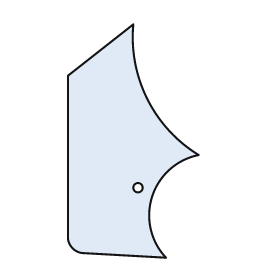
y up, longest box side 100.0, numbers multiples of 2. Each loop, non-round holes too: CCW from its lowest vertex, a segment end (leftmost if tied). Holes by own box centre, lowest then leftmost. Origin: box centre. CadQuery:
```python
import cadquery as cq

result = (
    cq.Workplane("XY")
    .moveTo(14.0, -50.0)
    .threePointArc((8.0, -24.0), (28.0, -6.0))
    .threePointArc((6.0, 18.0), (0.0, 50.0))
    .lineTo(-28.0, 28.0)
    .lineTo(-28.0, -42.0)
    .threePointArc((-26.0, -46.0), (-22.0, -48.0))
    .close()
    .moveTo(2.0, -20.0)
    .circle(2.0)
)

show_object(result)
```